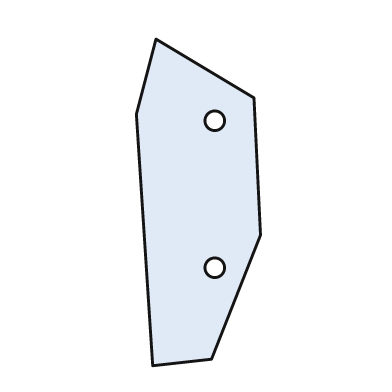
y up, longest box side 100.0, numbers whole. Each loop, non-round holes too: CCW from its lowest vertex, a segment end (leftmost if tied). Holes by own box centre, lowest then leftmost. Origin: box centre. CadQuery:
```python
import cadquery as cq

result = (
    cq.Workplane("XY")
    .moveTo(-14.0, -50.0)
    .lineTo(4.0, -48.0)
    .lineTo(19.0, -10.0)
    .lineTo(17.0, 32.0)
    .lineTo(-13.0, 50.0)
    .lineTo(-19.0, 27.0)
    .close()
    .moveTo(5.0, -20.0)
    .circle(3.0)
    .moveTo(5.0, 25.0)
    .circle(3.0)
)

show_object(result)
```